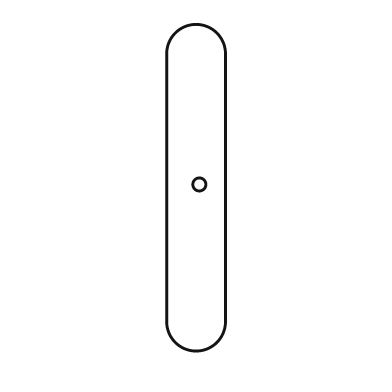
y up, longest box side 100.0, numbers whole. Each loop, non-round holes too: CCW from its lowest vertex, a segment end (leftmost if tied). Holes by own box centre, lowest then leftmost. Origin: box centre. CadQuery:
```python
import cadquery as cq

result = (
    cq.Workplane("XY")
    .moveTo(-9.0, -41.0)
    .threePointArc((0.0, -50.0), (9.0, -41.0))
    .lineTo(9.0, 41.0)
    .threePointArc((0.0, 50.0), (-9.0, 41.0))
    .close()
    .moveTo(1.0, 1.0)
    .circle(2.0)
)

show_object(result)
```